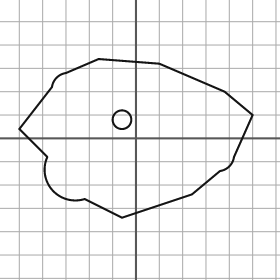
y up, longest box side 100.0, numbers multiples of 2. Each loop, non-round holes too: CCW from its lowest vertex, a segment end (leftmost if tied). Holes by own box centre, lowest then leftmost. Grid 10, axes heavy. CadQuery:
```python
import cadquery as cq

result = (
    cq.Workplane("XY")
    .moveTo(-6.0, -34.0)
    .lineTo(24.0, -24.0)
    .lineTo(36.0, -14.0)
    .threePointArc((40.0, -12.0), (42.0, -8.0))
    .lineTo(50.0, 10.0)
    .lineTo(38.0, 20.0)
    .lineTo(10.0, 32.0)
    .lineTo(-16.0, 34.0)
    .lineTo(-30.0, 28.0)
    .threePointArc((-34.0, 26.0), (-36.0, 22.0))
    .lineTo(-50.0, 4.0)
    .lineTo(-38.0, -8.0)
    .threePointArc((-36.0, -22.0), (-22.0, -26.0))
    .close()
    .moveTo(-6.0, 8.0)
    .circle(4.0)
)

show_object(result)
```